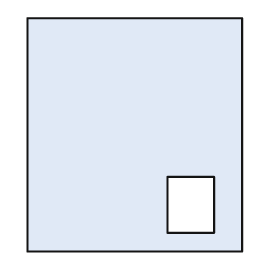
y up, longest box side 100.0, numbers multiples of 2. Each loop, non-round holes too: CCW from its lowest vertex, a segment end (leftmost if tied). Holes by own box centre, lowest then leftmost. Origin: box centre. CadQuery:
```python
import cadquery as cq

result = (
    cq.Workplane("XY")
    .moveTo(-46.0, -50.0)
    .lineTo(46.0, -50.0)
    .lineTo(46.0, 50.0)
    .lineTo(-46.0, 50.0)
    .close()
    .moveTo(14.0, -42.0)
    .lineTo(34.0, -42.0)
    .lineTo(34.0, -18.0)
    .lineTo(14.0, -18.0)
    .close()
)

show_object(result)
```